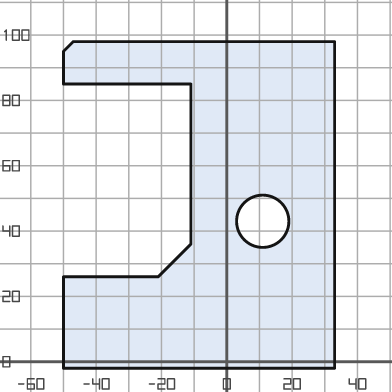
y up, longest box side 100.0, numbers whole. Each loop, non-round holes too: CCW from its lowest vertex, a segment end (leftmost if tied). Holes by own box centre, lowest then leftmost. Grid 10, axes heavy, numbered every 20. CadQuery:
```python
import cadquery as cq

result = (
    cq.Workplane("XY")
    .moveTo(-50.0, -2.0)
    .lineTo(33.0, -2.0)
    .lineTo(33.0, 98.0)
    .lineTo(-47.0, 98.0)
    .lineTo(-50.0, 95.0)
    .lineTo(-50.0, 85.0)
    .lineTo(-11.0, 85.0)
    .lineTo(-11.0, 36.0)
    .lineTo(-21.0, 26.0)
    .lineTo(-50.0, 26.0)
    .close()
    .moveTo(11.0, 43.0)
    .circle(8.0)
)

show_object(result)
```